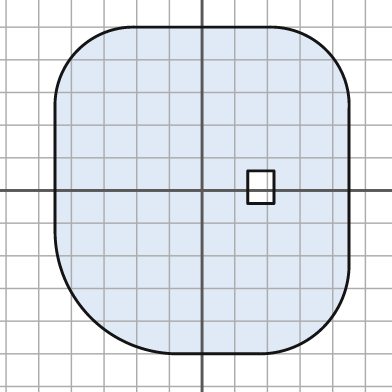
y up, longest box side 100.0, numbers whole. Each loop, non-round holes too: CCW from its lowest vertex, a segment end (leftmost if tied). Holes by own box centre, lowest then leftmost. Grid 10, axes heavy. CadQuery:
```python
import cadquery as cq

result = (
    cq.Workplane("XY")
    .moveTo(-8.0, -50.0)
    .lineTo(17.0, -50.0)
    .threePointArc((37.0, -42.0), (45.0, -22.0))
    .lineTo(45.0, 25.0)
    .threePointArc((38.0, 43.0), (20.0, 50.0))
    .lineTo(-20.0, 50.0)
    .threePointArc((-38.0, 43.0), (-45.0, 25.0))
    .lineTo(-45.0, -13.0)
    .threePointArc((-34.0, -39.0), (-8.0, -50.0))
    .close()
    .moveTo(14.0, -4.0)
    .lineTo(22.0, -4.0)
    .lineTo(22.0, 6.0)
    .lineTo(14.0, 6.0)
    .close()
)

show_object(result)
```